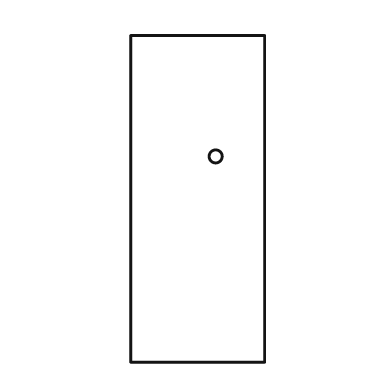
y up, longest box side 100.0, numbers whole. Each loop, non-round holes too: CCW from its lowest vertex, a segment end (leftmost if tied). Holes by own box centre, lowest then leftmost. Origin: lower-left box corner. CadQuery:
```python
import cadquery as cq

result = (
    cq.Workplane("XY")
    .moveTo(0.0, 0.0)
    .lineTo(41.0, 0.0)
    .lineTo(41.0, 100.0)
    .lineTo(0.0, 100.0)
    .close()
    .moveTo(26.0, 63.0)
    .circle(2.0)
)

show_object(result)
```